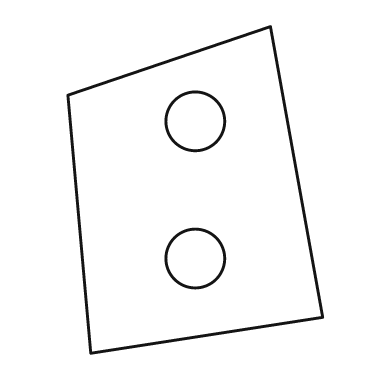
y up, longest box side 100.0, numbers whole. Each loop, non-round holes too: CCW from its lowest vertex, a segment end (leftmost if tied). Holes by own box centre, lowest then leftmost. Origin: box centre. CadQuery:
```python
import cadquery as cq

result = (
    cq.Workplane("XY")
    .moveTo(-32.0, -50.0)
    .lineTo(39.0, -39.0)
    .lineTo(23.0, 50.0)
    .lineTo(-39.0, 29.0)
    .close()
    .moveTo(0.0, -21.0)
    .circle(9.0)
    .moveTo(0.0, 21.0)
    .circle(9.0)
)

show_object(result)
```